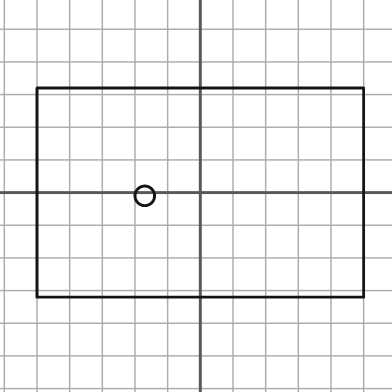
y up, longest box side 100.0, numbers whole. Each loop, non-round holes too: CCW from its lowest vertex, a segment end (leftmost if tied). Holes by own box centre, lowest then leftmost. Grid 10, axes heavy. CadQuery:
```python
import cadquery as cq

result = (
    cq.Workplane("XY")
    .moveTo(-50.0, -32.0)
    .lineTo(50.0, -32.0)
    .lineTo(50.0, 32.0)
    .lineTo(-50.0, 32.0)
    .close()
    .moveTo(-17.0, -1.0)
    .circle(3.0)
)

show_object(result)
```